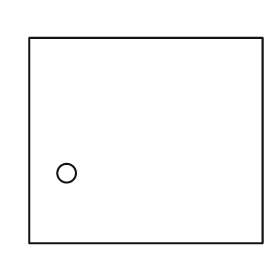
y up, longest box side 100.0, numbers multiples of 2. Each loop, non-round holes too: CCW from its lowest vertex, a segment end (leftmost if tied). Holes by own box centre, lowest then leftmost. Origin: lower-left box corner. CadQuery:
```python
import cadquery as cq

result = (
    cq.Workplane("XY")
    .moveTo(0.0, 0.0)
    .lineTo(100.0, 0.0)
    .lineTo(100.0, 88.0)
    .lineTo(0.0, 88.0)
    .close()
    .moveTo(16.0, 30.0)
    .circle(4.0)
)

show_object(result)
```